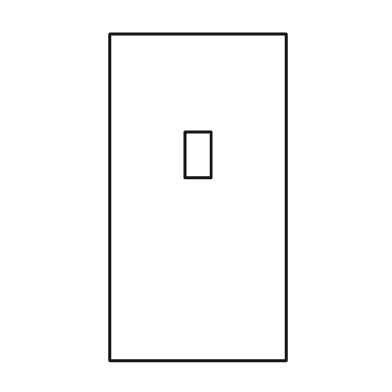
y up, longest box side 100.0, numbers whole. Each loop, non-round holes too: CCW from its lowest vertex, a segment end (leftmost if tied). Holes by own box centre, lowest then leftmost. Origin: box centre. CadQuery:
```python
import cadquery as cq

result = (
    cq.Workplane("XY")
    .moveTo(-27.0, -50.0)
    .lineTo(27.0, -50.0)
    .lineTo(27.0, 50.0)
    .lineTo(-27.0, 50.0)
    .close()
    .moveTo(-4.0, 6.0)
    .lineTo(4.0, 6.0)
    .lineTo(4.0, 20.0)
    .lineTo(-4.0, 20.0)
    .close()
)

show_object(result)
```